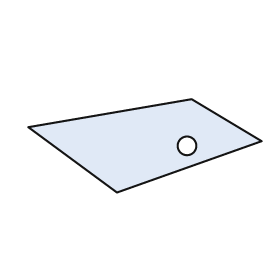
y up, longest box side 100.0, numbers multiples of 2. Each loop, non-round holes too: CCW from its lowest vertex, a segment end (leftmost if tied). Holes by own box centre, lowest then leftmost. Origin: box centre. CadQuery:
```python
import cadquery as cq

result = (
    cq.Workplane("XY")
    .moveTo(-12.0, -20.0)
    .lineTo(50.0, 2.0)
    .lineTo(20.0, 20.0)
    .lineTo(-50.0, 8.0)
    .close()
    .moveTo(18.0, 0.0)
    .circle(4.0)
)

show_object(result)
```